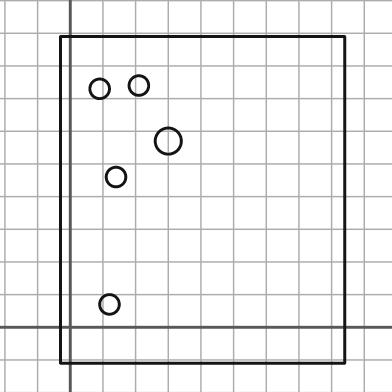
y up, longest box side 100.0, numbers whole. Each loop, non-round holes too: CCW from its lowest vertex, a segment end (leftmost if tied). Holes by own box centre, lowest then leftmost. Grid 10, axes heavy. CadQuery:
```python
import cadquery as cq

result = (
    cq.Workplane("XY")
    .moveTo(-3.0, -11.0)
    .lineTo(84.0, -11.0)
    .lineTo(84.0, 89.0)
    .lineTo(-3.0, 89.0)
    .close()
    .moveTo(12.0, 7.0)
    .circle(3.0)
    .moveTo(14.0, 46.0)
    .circle(3.0)
    .moveTo(30.0, 57.0)
    .circle(4.0)
    .moveTo(9.0, 73.0)
    .circle(3.0)
    .moveTo(21.0, 74.0)
    .circle(3.0)
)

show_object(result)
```